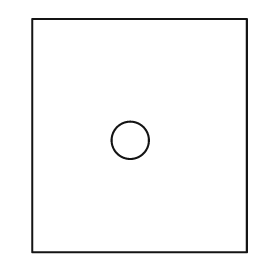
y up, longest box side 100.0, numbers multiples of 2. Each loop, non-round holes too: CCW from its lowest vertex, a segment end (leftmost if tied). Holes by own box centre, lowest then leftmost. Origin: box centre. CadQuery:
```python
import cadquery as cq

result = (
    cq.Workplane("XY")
    .moveTo(-46.0, -50.0)
    .lineTo(46.0, -50.0)
    .lineTo(46.0, 50.0)
    .lineTo(-46.0, 50.0)
    .close()
    .moveTo(-4.0, -2.0)
    .circle(8.0)
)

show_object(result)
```